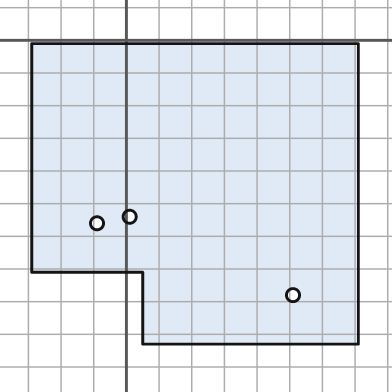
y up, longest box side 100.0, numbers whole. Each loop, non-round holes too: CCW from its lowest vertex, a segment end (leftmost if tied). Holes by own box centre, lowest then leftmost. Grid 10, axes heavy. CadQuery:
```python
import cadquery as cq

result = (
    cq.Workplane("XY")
    .moveTo(5.0, -93.0)
    .lineTo(71.0, -93.0)
    .lineTo(71.0, -1.0)
    .lineTo(-29.0, -1.0)
    .lineTo(-29.0, -71.0)
    .lineTo(5.0, -71.0)
    .close()
    .moveTo(51.0, -78.0)
    .circle(2.0)
    .moveTo(-9.0, -56.0)
    .circle(2.0)
    .moveTo(1.0, -54.0)
    .circle(2.0)
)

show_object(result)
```